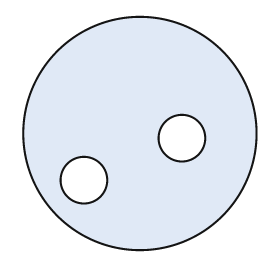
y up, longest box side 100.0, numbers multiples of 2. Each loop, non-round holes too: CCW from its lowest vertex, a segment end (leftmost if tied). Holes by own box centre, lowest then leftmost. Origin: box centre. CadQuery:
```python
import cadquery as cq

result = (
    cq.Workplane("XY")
    .moveTo(0.0, 0.0)
    .circle(50.0)
    .moveTo(-24.0, -20.0)
    .circle(10.0)
    .moveTo(18.0, -2.0)
    .circle(10.0)
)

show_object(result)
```